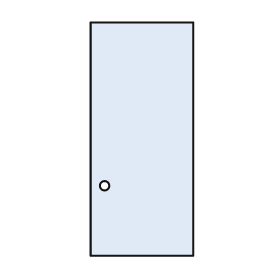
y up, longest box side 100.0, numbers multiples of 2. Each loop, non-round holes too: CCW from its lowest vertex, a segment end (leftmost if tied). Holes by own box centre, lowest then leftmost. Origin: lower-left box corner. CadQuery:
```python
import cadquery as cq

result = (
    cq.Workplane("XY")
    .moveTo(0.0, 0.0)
    .lineTo(44.0, 0.0)
    .lineTo(44.0, 100.0)
    .lineTo(0.0, 100.0)
    .close()
    .moveTo(6.0, 30.0)
    .circle(2.0)
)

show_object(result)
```